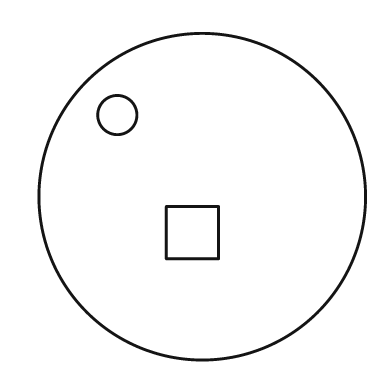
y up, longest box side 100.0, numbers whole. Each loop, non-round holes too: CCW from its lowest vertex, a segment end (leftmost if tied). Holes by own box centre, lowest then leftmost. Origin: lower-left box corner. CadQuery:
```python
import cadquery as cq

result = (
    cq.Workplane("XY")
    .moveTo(50.0, 50.0)
    .circle(50.0)
    .moveTo(39.0, 31.0)
    .lineTo(55.0, 31.0)
    .lineTo(55.0, 47.0)
    .lineTo(39.0, 47.0)
    .close()
    .moveTo(24.0, 75.0)
    .circle(6.0)
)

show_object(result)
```